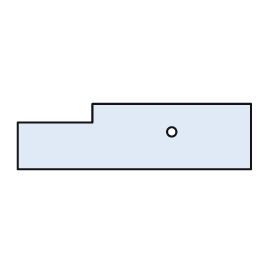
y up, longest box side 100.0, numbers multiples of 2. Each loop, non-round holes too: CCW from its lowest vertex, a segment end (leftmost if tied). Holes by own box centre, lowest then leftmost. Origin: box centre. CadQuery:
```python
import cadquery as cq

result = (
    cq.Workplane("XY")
    .moveTo(-50.0, -14.0)
    .lineTo(50.0, -14.0)
    .lineTo(50.0, 14.0)
    .lineTo(-18.0, 14.0)
    .lineTo(-18.0, 6.0)
    .lineTo(-50.0, 6.0)
    .close()
    .moveTo(16.0, 2.0)
    .circle(2.0)
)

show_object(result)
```